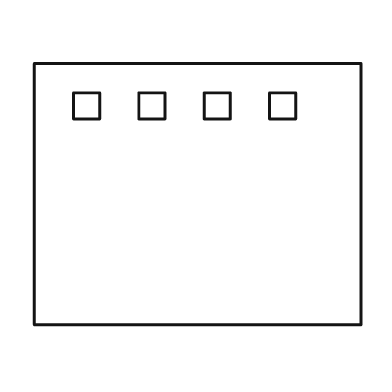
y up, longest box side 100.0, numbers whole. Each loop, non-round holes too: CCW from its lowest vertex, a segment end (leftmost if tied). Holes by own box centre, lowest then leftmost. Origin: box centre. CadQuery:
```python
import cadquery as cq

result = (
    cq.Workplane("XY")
    .moveTo(-50.0, -40.0)
    .lineTo(50.0, -40.0)
    .lineTo(50.0, 40.0)
    .lineTo(-50.0, 40.0)
    .close()
    .moveTo(-38.0, 23.0)
    .lineTo(-30.0, 23.0)
    .lineTo(-30.0, 31.0)
    .lineTo(-38.0, 31.0)
    .close()
    .moveTo(-18.0, 23.0)
    .lineTo(-10.0, 23.0)
    .lineTo(-10.0, 31.0)
    .lineTo(-18.0, 31.0)
    .close()
    .moveTo(2.0, 23.0)
    .lineTo(10.0, 23.0)
    .lineTo(10.0, 31.0)
    .lineTo(2.0, 31.0)
    .close()
    .moveTo(22.0, 23.0)
    .lineTo(30.0, 23.0)
    .lineTo(30.0, 31.0)
    .lineTo(22.0, 31.0)
    .close()
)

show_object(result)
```